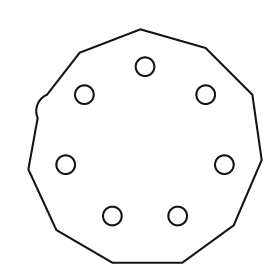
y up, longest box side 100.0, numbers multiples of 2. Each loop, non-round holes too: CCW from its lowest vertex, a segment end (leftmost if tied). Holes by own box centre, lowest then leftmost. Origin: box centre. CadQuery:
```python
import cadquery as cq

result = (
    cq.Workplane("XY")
    .moveTo(-14.0, -50.0)
    .lineTo(16.0, -50.0)
    .lineTo(38.0, -34.0)
    .lineTo(50.0, -6.0)
    .lineTo(46.0, 22.0)
    .lineTo(26.0, 42.0)
    .lineTo(-2.0, 50.0)
    .lineTo(-28.0, 40.0)
    .lineTo(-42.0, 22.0)
    .threePointArc((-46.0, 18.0), (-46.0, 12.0))
    .lineTo(-50.0, -10.0)
    .lineTo(-38.0, -36.0)
    .close()
    .moveTo(-14.0, -30.0)
    .circle(4.0)
    .moveTo(14.0, -30.0)
    .circle(4.0)
    .moveTo(-34.0, -8.0)
    .circle(4.0)
    .moveTo(34.0, -8.0)
    .circle(4.0)
    .moveTo(-26.0, 22.0)
    .circle(4.0)
    .moveTo(26.0, 22.0)
    .circle(4.0)
    .moveTo(0.0, 34.0)
    .circle(4.0)
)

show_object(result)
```